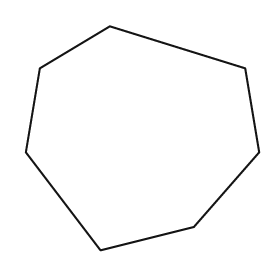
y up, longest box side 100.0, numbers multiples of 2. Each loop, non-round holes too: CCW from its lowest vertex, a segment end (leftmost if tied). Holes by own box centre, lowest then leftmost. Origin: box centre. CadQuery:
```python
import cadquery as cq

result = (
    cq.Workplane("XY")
    .moveTo(-18.0, -48.0)
    .lineTo(22.0, -38.0)
    .lineTo(50.0, -6.0)
    .lineTo(44.0, 30.0)
    .lineTo(-14.0, 48.0)
    .lineTo(-44.0, 30.0)
    .lineTo(-50.0, -6.0)
    .close()
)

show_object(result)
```